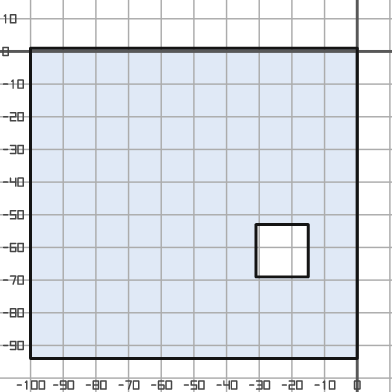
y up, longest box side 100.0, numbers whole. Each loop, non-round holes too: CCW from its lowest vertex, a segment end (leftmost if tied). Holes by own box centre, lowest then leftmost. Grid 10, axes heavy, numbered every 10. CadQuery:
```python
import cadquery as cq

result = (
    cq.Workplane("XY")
    .moveTo(-100.0, -94.0)
    .lineTo(0.0, -94.0)
    .lineTo(0.0, 1.0)
    .lineTo(-100.0, 1.0)
    .close()
    .moveTo(-31.0, -69.0)
    .lineTo(-15.0, -69.0)
    .lineTo(-15.0, -53.0)
    .lineTo(-31.0, -53.0)
    .close()
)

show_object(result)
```